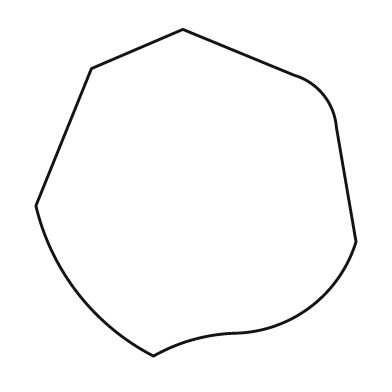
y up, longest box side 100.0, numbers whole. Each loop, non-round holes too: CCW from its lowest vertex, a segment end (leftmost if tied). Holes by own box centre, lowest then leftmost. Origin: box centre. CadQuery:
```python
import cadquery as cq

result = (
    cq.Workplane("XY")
    .moveTo(-13.0, -50.0)
    .threePointArc((-1.0, -45.0), (12.0, -43.0))
    .threePointArc((35.0, -35.0), (49.0, -15.0))
    .lineTo(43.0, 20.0)
    .threePointArc((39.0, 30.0), (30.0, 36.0))
    .lineTo(-4.0, 50.0)
    .lineTo(-32.0, 38.0)
    .lineTo(-49.0, -4.0)
    .threePointArc((-36.0, -31.0), (-13.0, -50.0))
    .close()
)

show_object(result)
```